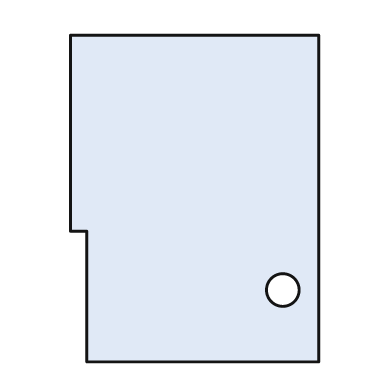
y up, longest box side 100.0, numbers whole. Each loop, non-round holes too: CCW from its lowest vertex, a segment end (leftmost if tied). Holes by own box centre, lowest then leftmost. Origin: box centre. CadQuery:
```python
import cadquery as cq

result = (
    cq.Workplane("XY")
    .moveTo(-33.0, -50.0)
    .lineTo(38.0, -50.0)
    .lineTo(38.0, 50.0)
    .lineTo(-38.0, 50.0)
    .lineTo(-38.0, -10.0)
    .lineTo(-33.0, -10.0)
    .close()
    .moveTo(27.0, -28.0)
    .circle(5.0)
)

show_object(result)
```